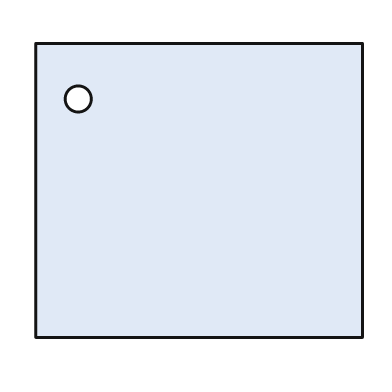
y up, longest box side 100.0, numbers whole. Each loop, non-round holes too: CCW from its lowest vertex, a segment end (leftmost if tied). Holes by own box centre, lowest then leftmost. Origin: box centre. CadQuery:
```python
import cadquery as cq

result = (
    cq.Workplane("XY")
    .moveTo(-50.0, -45.0)
    .lineTo(50.0, -45.0)
    .lineTo(50.0, 45.0)
    .lineTo(-50.0, 45.0)
    .close()
    .moveTo(-37.0, 28.0)
    .circle(4.0)
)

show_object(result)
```